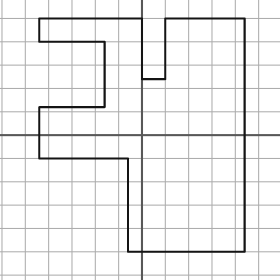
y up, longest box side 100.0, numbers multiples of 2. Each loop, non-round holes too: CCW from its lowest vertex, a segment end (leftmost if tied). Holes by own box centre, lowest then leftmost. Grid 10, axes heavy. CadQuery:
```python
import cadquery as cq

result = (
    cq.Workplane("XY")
    .moveTo(-6.0, -50.0)
    .lineTo(44.0, -50.0)
    .lineTo(44.0, 50.0)
    .lineTo(10.0, 50.0)
    .lineTo(10.0, 24.0)
    .lineTo(0.0, 24.0)
    .lineTo(0.0, 50.0)
    .lineTo(-44.0, 50.0)
    .lineTo(-44.0, 40.0)
    .lineTo(-16.0, 40.0)
    .lineTo(-16.0, 12.0)
    .lineTo(-44.0, 12.0)
    .lineTo(-44.0, -10.0)
    .lineTo(-6.0, -10.0)
    .close()
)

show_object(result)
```